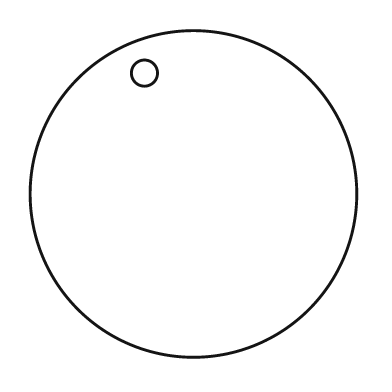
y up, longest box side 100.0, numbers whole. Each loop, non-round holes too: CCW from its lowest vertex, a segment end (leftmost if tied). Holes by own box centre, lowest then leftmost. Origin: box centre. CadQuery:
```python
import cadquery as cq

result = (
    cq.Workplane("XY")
    .moveTo(0.0, 0.0)
    .circle(50.0)
    .moveTo(-15.0, 37.0)
    .circle(4.0)
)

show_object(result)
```